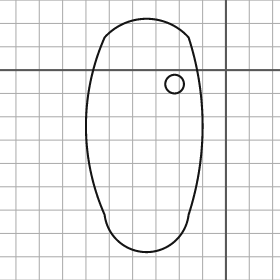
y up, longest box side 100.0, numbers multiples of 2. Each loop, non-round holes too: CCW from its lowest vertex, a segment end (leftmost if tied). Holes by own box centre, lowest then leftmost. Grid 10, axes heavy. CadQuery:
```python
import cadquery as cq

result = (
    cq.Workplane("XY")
    .moveTo(-52.0, -62.0)
    .threePointArc((-34.0, -78.0), (-16.0, -62.0))
    .threePointArc((-10.0, -24.0), (-16.0, 14.0))
    .threePointArc((-34.0, 22.0), (-52.0, 14.0))
    .threePointArc((-60.0, -24.0), (-52.0, -62.0))
    .close()
    .moveTo(-22.0, -6.0)
    .circle(4.0)
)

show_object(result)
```